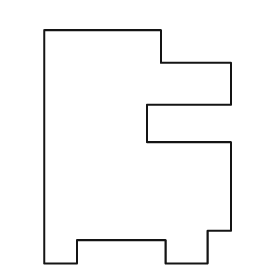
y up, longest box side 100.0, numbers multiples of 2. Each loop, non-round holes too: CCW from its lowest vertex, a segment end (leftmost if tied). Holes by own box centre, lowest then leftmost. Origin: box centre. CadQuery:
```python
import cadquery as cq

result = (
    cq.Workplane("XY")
    .moveTo(-40.0, -50.0)
    .lineTo(-26.0, -50.0)
    .lineTo(-26.0, -40.0)
    .lineTo(12.0, -40.0)
    .lineTo(12.0, -50.0)
    .lineTo(30.0, -50.0)
    .lineTo(30.0, -36.0)
    .lineTo(40.0, -36.0)
    .lineTo(40.0, 2.0)
    .lineTo(4.0, 2.0)
    .lineTo(4.0, 18.0)
    .lineTo(40.0, 18.0)
    .lineTo(40.0, 36.0)
    .lineTo(10.0, 36.0)
    .lineTo(10.0, 50.0)
    .lineTo(-40.0, 50.0)
    .close()
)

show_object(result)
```